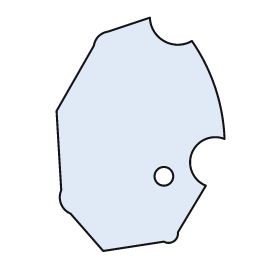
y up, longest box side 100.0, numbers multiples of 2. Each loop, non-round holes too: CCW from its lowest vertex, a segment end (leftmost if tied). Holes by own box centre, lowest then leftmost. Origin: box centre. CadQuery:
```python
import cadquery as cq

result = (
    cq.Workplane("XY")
    .moveTo(-16.0, -50.0)
    .lineTo(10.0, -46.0)
    .threePointArc((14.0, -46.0), (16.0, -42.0))
    .lineTo(28.0, -22.0)
    .threePointArc((22.0, -8.0), (36.0, -2.0))
    .threePointArc((32.0, 20.0), (22.0, 40.0))
    .threePointArc((10.0, 40.0), (4.0, 50.0))
    .lineTo(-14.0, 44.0)
    .threePointArc((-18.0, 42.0), (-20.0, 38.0))
    .lineTo(-36.0, 10.0)
    .lineTo(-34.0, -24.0)
    .threePointArc((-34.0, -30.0), (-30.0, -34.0))
    .close()
    .moveTo(10.0, -18.0)
    .circle(4.0)
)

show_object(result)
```